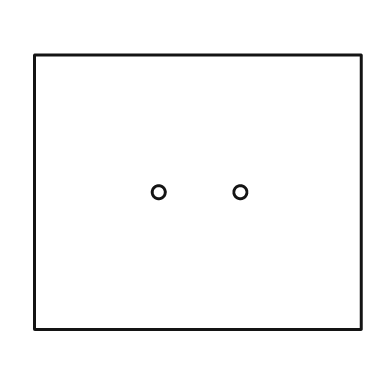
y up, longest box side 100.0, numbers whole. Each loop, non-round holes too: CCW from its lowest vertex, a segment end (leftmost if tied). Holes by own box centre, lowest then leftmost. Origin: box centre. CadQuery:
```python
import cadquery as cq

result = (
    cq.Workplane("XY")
    .moveTo(-50.0, -42.0)
    .lineTo(50.0, -42.0)
    .lineTo(50.0, 42.0)
    .lineTo(-50.0, 42.0)
    .close()
    .moveTo(-12.0, 0.0)
    .circle(2.0)
    .moveTo(13.0, 0.0)
    .circle(2.0)
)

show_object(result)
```